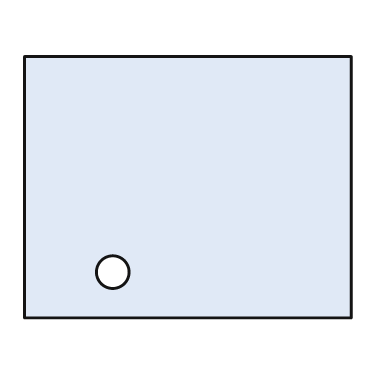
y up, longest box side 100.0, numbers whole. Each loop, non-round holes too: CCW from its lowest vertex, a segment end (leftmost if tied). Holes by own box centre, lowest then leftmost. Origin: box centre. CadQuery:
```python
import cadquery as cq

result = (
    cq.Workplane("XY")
    .moveTo(-50.0, -40.0)
    .lineTo(50.0, -40.0)
    .lineTo(50.0, 40.0)
    .lineTo(-50.0, 40.0)
    .close()
    .moveTo(-23.0, -26.0)
    .circle(5.0)
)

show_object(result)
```